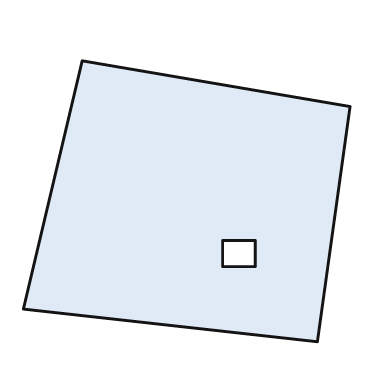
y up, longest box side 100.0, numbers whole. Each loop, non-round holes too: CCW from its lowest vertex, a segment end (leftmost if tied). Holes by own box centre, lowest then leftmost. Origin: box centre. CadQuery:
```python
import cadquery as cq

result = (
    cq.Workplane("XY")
    .moveTo(40.0, -43.0)
    .lineTo(50.0, 29.0)
    .lineTo(-32.0, 43.0)
    .lineTo(-50.0, -33.0)
    .close()
    .moveTo(11.0, -20.0)
    .lineTo(21.0, -20.0)
    .lineTo(21.0, -12.0)
    .lineTo(11.0, -12.0)
    .close()
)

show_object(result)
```